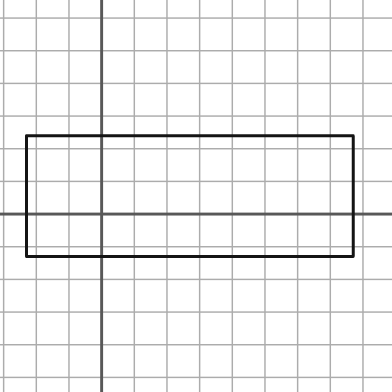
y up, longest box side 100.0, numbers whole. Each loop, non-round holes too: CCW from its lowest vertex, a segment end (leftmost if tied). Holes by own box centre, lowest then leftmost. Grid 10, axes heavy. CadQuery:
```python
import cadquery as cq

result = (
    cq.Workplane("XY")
    .moveTo(-23.0, -13.0)
    .lineTo(77.0, -13.0)
    .lineTo(77.0, 24.0)
    .lineTo(-23.0, 24.0)
    .close()
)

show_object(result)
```